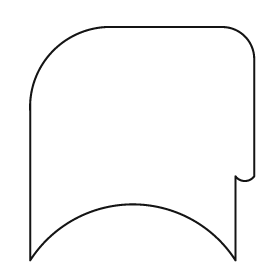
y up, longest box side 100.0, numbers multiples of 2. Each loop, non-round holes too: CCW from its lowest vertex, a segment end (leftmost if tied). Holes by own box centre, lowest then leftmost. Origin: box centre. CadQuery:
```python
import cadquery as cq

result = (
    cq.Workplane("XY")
    .moveTo(-48.0, -50.0)
    .threePointArc((-4.0, -26.0), (40.0, -50.0))
    .lineTo(40.0, -14.0)
    .threePointArc((44.0, -16.0), (48.0, -14.0))
    .lineTo(48.0, 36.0)
    .threePointArc((44.0, 46.0), (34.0, 50.0))
    .lineTo(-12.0, 50.0)
    .threePointArc((-38.0, 40.0), (-48.0, 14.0))
    .close()
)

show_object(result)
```